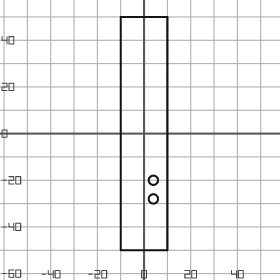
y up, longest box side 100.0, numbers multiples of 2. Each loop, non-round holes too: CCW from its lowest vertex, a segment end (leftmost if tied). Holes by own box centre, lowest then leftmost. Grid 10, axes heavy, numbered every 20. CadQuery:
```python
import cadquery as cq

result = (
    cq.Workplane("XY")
    .moveTo(-10.0, -50.0)
    .lineTo(10.0, -50.0)
    .lineTo(10.0, 50.0)
    .lineTo(-10.0, 50.0)
    .close()
    .moveTo(4.0, -28.0)
    .circle(2.0)
    .moveTo(4.0, -20.0)
    .circle(2.0)
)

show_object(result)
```